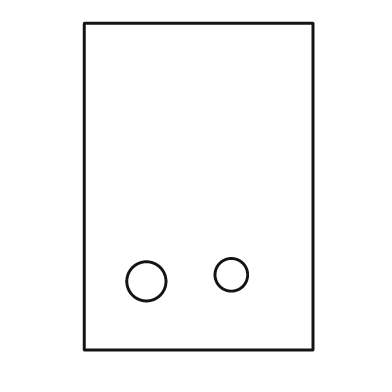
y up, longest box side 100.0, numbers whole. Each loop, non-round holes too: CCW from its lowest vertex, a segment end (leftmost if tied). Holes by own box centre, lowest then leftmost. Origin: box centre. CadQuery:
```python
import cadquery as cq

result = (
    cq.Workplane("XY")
    .moveTo(-35.0, -50.0)
    .lineTo(35.0, -50.0)
    .lineTo(35.0, 50.0)
    .lineTo(-35.0, 50.0)
    .close()
    .moveTo(-16.0, -29.0)
    .circle(6.0)
    .moveTo(10.0, -27.0)
    .circle(5.0)
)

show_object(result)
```